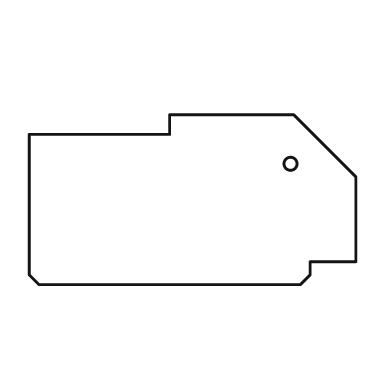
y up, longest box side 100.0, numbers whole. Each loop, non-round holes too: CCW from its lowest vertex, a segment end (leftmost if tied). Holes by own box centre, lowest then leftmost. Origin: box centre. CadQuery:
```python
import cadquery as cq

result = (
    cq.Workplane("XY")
    .moveTo(-47.0, -26.0)
    .lineTo(33.0, -26.0)
    .lineTo(36.0, -23.0)
    .lineTo(36.0, -19.0)
    .lineTo(50.0, -19.0)
    .lineTo(50.0, 7.0)
    .lineTo(31.0, 26.0)
    .lineTo(-7.0, 26.0)
    .lineTo(-7.0, 20.0)
    .lineTo(-50.0, 20.0)
    .lineTo(-50.0, -23.0)
    .close()
    .moveTo(30.0, 11.0)
    .circle(2.0)
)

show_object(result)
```